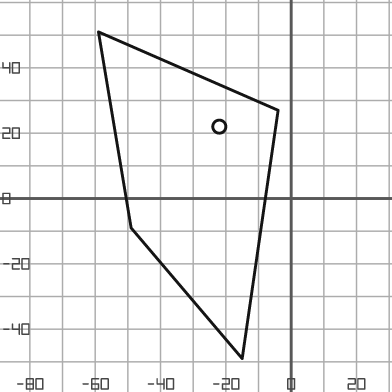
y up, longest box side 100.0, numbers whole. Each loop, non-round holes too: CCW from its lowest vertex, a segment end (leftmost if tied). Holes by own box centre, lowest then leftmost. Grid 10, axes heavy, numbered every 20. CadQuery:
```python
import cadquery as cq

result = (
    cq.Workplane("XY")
    .moveTo(-15.0, -49.0)
    .lineTo(-4.0, 27.0)
    .lineTo(-59.0, 51.0)
    .lineTo(-49.0, -9.0)
    .close()
    .moveTo(-22.0, 22.0)
    .circle(2.0)
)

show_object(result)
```